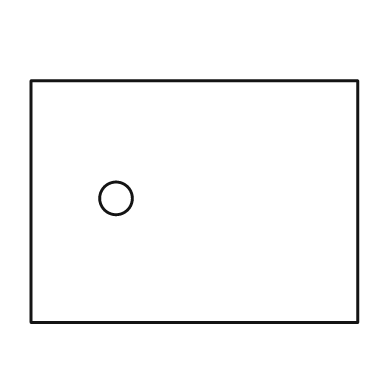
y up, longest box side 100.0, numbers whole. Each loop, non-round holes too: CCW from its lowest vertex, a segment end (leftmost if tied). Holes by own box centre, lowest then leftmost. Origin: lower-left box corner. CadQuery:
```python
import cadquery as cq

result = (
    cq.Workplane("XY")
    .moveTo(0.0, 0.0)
    .lineTo(100.0, 0.0)
    .lineTo(100.0, 74.0)
    .lineTo(0.0, 74.0)
    .close()
    .moveTo(26.0, 38.0)
    .circle(5.0)
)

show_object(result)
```